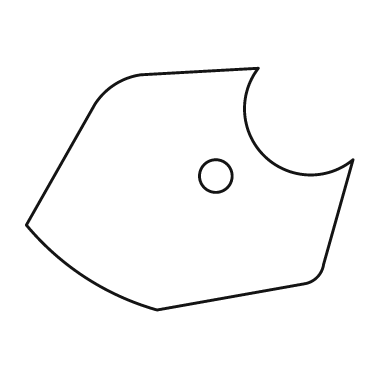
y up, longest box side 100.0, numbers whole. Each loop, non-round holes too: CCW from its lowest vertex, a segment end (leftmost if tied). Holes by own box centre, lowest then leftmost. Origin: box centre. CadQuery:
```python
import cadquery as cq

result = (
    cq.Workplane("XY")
    .moveTo(-10.0, -37.0)
    .lineTo(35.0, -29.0)
    .threePointArc((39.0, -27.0), (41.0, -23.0))
    .lineTo(50.0, 9.0)
    .threePointArc((23.0, 10.0), (21.0, 37.0))
    .lineTo(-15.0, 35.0)
    .threePointArc((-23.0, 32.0), (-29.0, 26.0))
    .lineTo(-50.0, -11.0)
    .threePointArc((-32.0, -27.0), (-10.0, -37.0))
    .close()
    .moveTo(8.0, 4.0)
    .circle(5.0)
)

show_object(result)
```